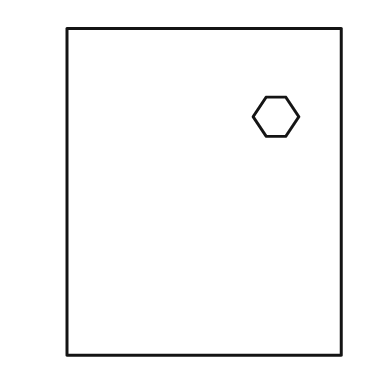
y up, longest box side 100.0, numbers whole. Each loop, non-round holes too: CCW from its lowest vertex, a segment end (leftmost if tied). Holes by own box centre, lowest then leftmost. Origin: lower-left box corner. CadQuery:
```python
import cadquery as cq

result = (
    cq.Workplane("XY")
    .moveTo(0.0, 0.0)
    .lineTo(84.0, 0.0)
    .lineTo(84.0, 100.0)
    .lineTo(0.0, 100.0)
    .close()
    .moveTo(61.0, 67.0)
    .lineTo(67.0, 67.0)
    .lineTo(71.0, 73.0)
    .lineTo(67.0, 79.0)
    .lineTo(61.0, 79.0)
    .lineTo(57.0, 73.0)
    .close()
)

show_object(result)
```